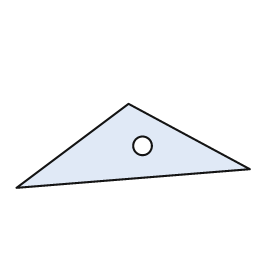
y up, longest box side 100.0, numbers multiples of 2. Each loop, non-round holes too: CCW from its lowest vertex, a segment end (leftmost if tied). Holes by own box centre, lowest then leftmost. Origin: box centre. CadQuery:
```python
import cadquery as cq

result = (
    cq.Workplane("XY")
    .moveTo(-50.0, -18.0)
    .lineTo(50.0, -10.0)
    .lineTo(-2.0, 18.0)
    .close()
    .moveTo(4.0, 0.0)
    .circle(4.0)
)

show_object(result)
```